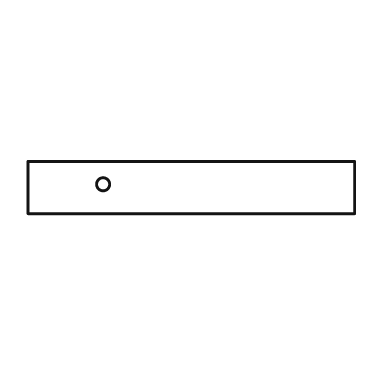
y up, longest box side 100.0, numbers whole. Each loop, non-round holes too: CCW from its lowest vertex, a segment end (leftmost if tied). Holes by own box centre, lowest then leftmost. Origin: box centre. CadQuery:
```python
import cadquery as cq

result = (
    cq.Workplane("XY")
    .moveTo(-50.0, -8.0)
    .lineTo(50.0, -8.0)
    .lineTo(50.0, 8.0)
    .lineTo(-50.0, 8.0)
    .close()
    .moveTo(-27.0, 1.0)
    .circle(2.0)
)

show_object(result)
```